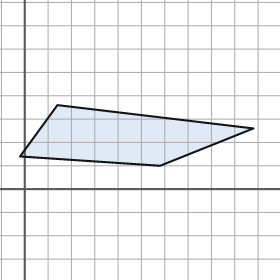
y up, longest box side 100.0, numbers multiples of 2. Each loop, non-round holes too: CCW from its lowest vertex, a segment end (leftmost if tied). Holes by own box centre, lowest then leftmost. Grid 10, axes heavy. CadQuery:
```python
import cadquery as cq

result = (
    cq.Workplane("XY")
    .moveTo(58.0, 10.0)
    .lineTo(98.0, 26.0)
    .lineTo(14.0, 36.0)
    .lineTo(-2.0, 14.0)
    .close()
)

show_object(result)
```